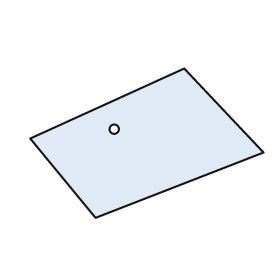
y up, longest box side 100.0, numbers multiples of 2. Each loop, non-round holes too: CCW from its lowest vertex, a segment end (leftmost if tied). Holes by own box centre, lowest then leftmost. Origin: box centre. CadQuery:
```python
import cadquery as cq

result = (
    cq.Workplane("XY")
    .moveTo(-22.0, -32.0)
    .lineTo(50.0, -4.0)
    .lineTo(16.0, 32.0)
    .lineTo(-50.0, 2.0)
    .close()
    .moveTo(-14.0, 6.0)
    .circle(2.0)
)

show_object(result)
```